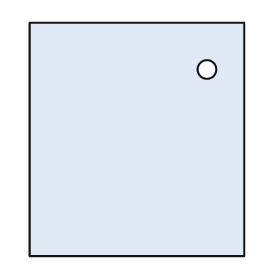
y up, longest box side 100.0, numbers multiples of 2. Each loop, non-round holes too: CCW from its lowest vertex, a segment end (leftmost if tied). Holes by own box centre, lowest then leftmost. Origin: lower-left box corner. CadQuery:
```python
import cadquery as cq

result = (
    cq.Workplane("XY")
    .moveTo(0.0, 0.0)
    .lineTo(92.0, 0.0)
    .lineTo(92.0, 100.0)
    .lineTo(0.0, 100.0)
    .close()
    .moveTo(76.0, 80.0)
    .circle(4.0)
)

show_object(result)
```